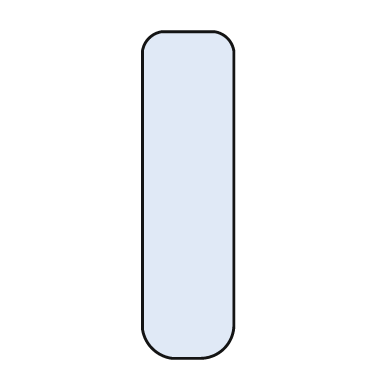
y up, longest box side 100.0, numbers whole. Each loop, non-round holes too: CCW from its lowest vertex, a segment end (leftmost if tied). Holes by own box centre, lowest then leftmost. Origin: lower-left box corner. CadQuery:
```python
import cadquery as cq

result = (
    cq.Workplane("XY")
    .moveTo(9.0, 0.0)
    .lineTo(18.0, 0.0)
    .threePointArc((25.0, 3.0), (28.0, 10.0))
    .lineTo(28.0, 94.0)
    .threePointArc((26.0, 98.0), (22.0, 100.0))
    .lineTo(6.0, 100.0)
    .threePointArc((2.0, 98.0), (0.0, 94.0))
    .lineTo(0.0, 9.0)
    .threePointArc((3.0, 3.0), (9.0, 0.0))
    .close()
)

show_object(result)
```